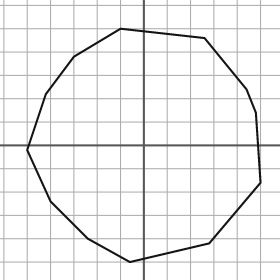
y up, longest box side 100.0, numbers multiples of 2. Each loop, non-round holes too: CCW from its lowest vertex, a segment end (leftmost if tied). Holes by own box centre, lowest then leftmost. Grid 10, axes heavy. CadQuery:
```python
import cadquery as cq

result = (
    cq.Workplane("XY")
    .moveTo(-6.0, -50.0)
    .lineTo(28.0, -42.0)
    .lineTo(50.0, -16.0)
    .lineTo(48.0, 14.0)
    .lineTo(44.0, 24.0)
    .lineTo(26.0, 46.0)
    .lineTo(-10.0, 50.0)
    .lineTo(-30.0, 38.0)
    .lineTo(-42.0, 22.0)
    .lineTo(-50.0, -2.0)
    .lineTo(-40.0, -24.0)
    .lineTo(-24.0, -40.0)
    .close()
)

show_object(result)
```